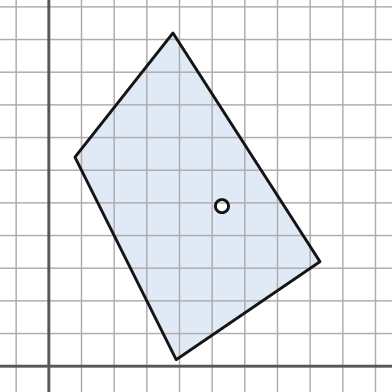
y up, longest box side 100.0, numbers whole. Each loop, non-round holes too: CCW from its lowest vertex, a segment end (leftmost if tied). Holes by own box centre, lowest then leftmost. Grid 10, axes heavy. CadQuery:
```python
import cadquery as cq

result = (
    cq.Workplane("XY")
    .moveTo(39.0, 2.0)
    .lineTo(83.0, 32.0)
    .lineTo(38.0, 102.0)
    .lineTo(8.0, 64.0)
    .close()
    .moveTo(53.0, 49.0)
    .circle(2.0)
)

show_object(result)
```